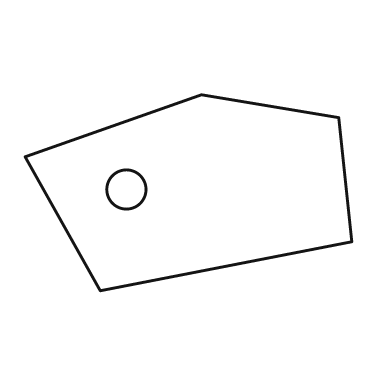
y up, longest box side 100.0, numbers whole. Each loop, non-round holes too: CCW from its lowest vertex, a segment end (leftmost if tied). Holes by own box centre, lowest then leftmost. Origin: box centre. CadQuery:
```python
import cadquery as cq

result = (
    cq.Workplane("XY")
    .moveTo(-27.0, -30.0)
    .lineTo(50.0, -15.0)
    .lineTo(46.0, 23.0)
    .lineTo(4.0, 30.0)
    .lineTo(-50.0, 11.0)
    .close()
    .moveTo(-19.0, 1.0)
    .circle(6.0)
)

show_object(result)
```